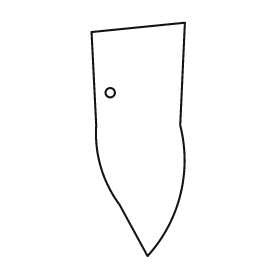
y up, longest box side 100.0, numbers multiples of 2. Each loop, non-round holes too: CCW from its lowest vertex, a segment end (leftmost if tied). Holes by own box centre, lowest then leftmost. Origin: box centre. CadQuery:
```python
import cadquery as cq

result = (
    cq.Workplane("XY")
    .moveTo(4.0, -50.0)
    .threePointArc((18.0, -24.0), (18.0, 6.0))
    .lineTo(20.0, 50.0)
    .lineTo(-20.0, 46.0)
    .lineTo(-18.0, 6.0)
    .threePointArc((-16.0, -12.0), (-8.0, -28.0))
    .close()
    .moveTo(-12.0, 20.0)
    .circle(2.0)
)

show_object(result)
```